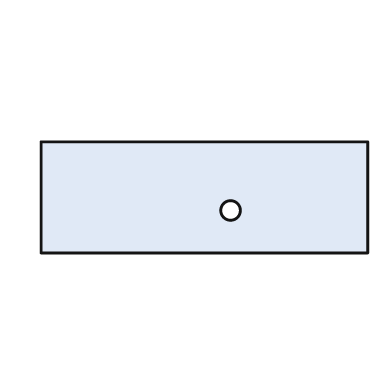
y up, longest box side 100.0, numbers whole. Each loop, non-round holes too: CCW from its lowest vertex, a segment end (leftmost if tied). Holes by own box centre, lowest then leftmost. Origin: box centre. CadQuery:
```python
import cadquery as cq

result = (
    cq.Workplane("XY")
    .moveTo(-50.0, -17.0)
    .lineTo(50.0, -17.0)
    .lineTo(50.0, 17.0)
    .lineTo(-50.0, 17.0)
    .close()
    .moveTo(8.0, -4.0)
    .circle(3.0)
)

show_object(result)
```